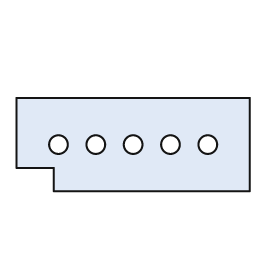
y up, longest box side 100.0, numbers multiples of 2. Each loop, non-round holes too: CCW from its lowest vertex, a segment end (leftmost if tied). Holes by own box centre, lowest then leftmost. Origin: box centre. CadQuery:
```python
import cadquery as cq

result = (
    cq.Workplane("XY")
    .moveTo(-34.0, -20.0)
    .lineTo(50.0, -20.0)
    .lineTo(50.0, 20.0)
    .lineTo(-50.0, 20.0)
    .lineTo(-50.0, -10.0)
    .lineTo(-34.0, -10.0)
    .close()
    .moveTo(-32.0, 0.0)
    .circle(4.0)
    .moveTo(-16.0, 0.0)
    .circle(4.0)
    .moveTo(0.0, 0.0)
    .circle(4.0)
    .moveTo(16.0, 0.0)
    .circle(4.0)
    .moveTo(32.0, 0.0)
    .circle(4.0)
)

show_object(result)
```